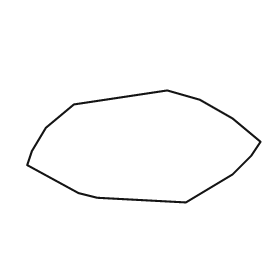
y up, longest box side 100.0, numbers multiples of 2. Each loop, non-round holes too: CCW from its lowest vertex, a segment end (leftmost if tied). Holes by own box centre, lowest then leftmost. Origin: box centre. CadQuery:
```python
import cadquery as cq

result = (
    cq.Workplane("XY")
    .moveTo(18.0, -24.0)
    .lineTo(38.0, -12.0)
    .lineTo(46.0, -4.0)
    .lineTo(50.0, 2.0)
    .lineTo(38.0, 12.0)
    .lineTo(24.0, 20.0)
    .lineTo(10.0, 24.0)
    .lineTo(-30.0, 18.0)
    .lineTo(-42.0, 8.0)
    .lineTo(-48.0, -2.0)
    .lineTo(-50.0, -8.0)
    .lineTo(-28.0, -20.0)
    .lineTo(-20.0, -22.0)
    .close()
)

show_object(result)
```